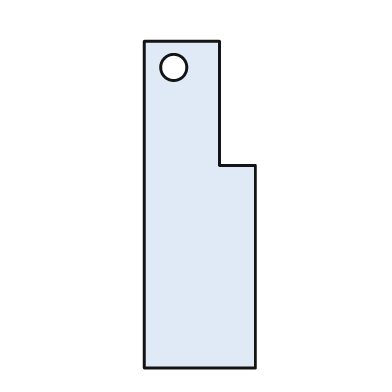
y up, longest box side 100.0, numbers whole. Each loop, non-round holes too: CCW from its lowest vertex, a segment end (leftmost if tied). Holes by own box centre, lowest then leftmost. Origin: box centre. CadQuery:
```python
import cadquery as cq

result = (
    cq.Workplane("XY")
    .moveTo(-17.0, -50.0)
    .lineTo(17.0, -50.0)
    .lineTo(17.0, 12.0)
    .lineTo(6.0, 12.0)
    .lineTo(6.0, 50.0)
    .lineTo(-17.0, 50.0)
    .close()
    .moveTo(-8.0, 42.0)
    .circle(4.0)
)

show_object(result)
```